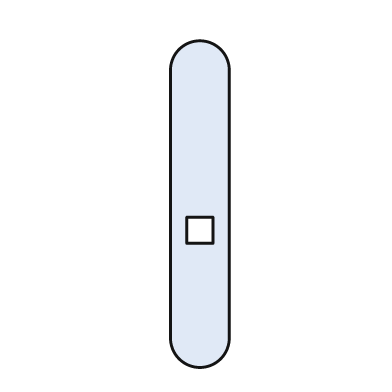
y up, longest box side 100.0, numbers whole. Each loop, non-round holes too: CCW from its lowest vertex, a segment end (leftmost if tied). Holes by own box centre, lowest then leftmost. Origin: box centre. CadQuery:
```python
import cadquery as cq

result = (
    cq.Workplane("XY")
    .moveTo(-9.0, -41.0)
    .threePointArc((0.0, -50.0), (9.0, -41.0))
    .lineTo(9.0, 41.0)
    .threePointArc((0.0, 50.0), (-9.0, 41.0))
    .close()
    .moveTo(-4.0, -12.0)
    .lineTo(4.0, -12.0)
    .lineTo(4.0, -4.0)
    .lineTo(-4.0, -4.0)
    .close()
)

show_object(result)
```